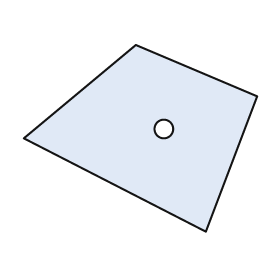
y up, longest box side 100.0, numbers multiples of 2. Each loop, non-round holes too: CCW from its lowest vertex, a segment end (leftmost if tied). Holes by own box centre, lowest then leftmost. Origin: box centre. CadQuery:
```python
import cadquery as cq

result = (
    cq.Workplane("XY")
    .moveTo(28.0, -40.0)
    .lineTo(50.0, 18.0)
    .lineTo(-2.0, 40.0)
    .lineTo(-50.0, 0.0)
    .close()
    .moveTo(10.0, 4.0)
    .circle(4.0)
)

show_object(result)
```